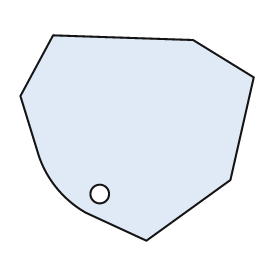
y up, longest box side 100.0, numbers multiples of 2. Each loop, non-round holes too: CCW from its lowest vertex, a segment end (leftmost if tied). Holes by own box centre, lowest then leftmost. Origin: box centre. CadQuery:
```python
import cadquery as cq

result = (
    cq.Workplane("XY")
    .moveTo(4.0, -44.0)
    .lineTo(40.0, -18.0)
    .lineTo(50.0, 26.0)
    .lineTo(24.0, 42.0)
    .lineTo(-36.0, 44.0)
    .lineTo(-50.0, 18.0)
    .lineTo(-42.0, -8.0)
    .threePointArc((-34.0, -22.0), (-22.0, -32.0))
    .close()
    .moveTo(-16.0, -24.0)
    .circle(4.0)
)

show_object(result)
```